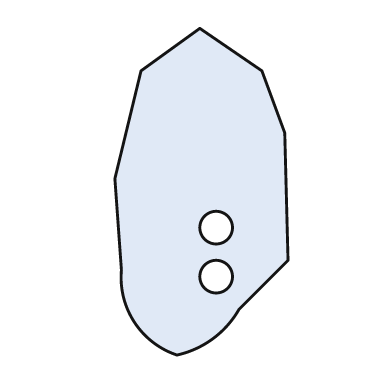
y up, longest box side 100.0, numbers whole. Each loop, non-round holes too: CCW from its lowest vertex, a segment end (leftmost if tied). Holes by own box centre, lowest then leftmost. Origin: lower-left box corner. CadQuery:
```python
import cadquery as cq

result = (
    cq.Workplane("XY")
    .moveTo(19.0, 0.0)
    .threePointArc((30.0, 5.0), (38.0, 14.0))
    .lineTo(53.0, 29.0)
    .lineTo(52.0, 68.0)
    .lineTo(45.0, 87.0)
    .lineTo(26.0, 100.0)
    .lineTo(8.0, 87.0)
    .lineTo(0.0, 54.0)
    .lineTo(2.0, 26.0)
    .threePointArc((6.0, 10.0), (19.0, 0.0))
    .close()
    .moveTo(31.0, 24.0)
    .circle(5.0)
    .moveTo(31.0, 39.0)
    .circle(5.0)
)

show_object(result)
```